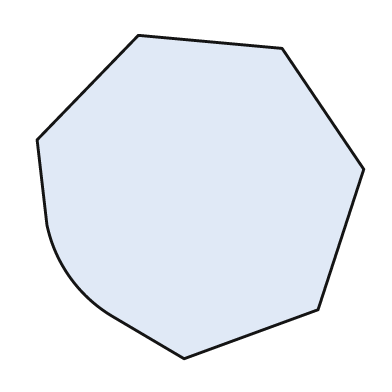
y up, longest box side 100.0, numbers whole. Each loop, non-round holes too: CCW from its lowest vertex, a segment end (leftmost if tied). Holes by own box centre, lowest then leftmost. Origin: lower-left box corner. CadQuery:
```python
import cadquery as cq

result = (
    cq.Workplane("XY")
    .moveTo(45.0, 0.0)
    .lineTo(86.0, 15.0)
    .lineTo(100.0, 58.0)
    .lineTo(75.0, 95.0)
    .lineTo(31.0, 99.0)
    .lineTo(0.0, 67.0)
    .lineTo(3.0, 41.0)
    .threePointArc((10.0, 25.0), (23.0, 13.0))
    .close()
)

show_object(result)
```